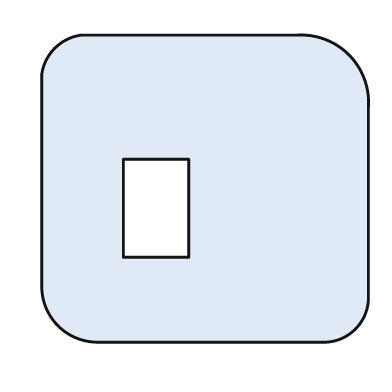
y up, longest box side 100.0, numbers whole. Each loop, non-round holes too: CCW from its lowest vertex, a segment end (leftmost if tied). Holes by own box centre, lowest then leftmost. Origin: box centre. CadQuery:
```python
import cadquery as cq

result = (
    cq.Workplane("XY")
    .moveTo(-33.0, -47.0)
    .lineTo(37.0, -47.0)
    .threePointArc((46.0, -43.0), (50.0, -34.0))
    .lineTo(50.0, 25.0)
    .threePointArc((44.0, 41.0), (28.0, 47.0))
    .lineTo(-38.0, 47.0)
    .threePointArc((-46.0, 43.0), (-50.0, 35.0))
    .lineTo(-50.0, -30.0)
    .threePointArc((-45.0, -42.0), (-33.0, -47.0))
    .close()
    .moveTo(-25.0, -21.0)
    .lineTo(-5.0, -21.0)
    .lineTo(-5.0, 9.0)
    .lineTo(-25.0, 9.0)
    .close()
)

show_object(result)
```